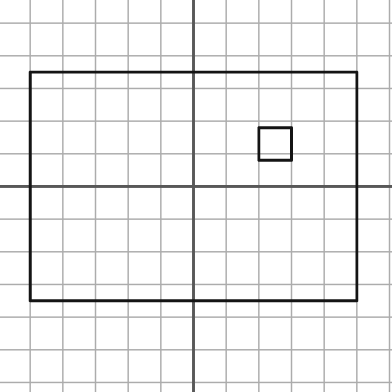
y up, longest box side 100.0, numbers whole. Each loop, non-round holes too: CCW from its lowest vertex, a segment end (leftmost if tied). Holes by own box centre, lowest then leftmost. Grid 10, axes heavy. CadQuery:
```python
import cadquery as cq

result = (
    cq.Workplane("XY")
    .moveTo(-50.0, -35.0)
    .lineTo(50.0, -35.0)
    .lineTo(50.0, 35.0)
    .lineTo(-50.0, 35.0)
    .close()
    .moveTo(20.0, 8.0)
    .lineTo(30.0, 8.0)
    .lineTo(30.0, 18.0)
    .lineTo(20.0, 18.0)
    .close()
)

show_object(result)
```